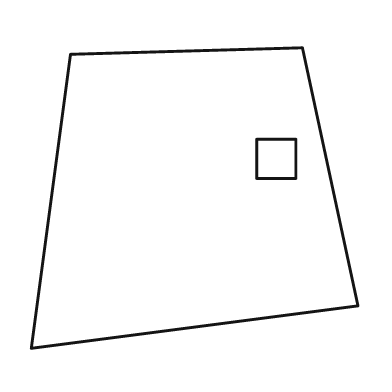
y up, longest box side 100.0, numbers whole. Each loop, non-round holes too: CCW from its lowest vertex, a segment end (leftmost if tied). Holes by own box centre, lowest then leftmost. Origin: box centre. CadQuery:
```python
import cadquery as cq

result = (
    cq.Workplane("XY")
    .moveTo(-50.0, -46.0)
    .lineTo(50.0, -33.0)
    .lineTo(33.0, 46.0)
    .lineTo(-38.0, 44.0)
    .close()
    .moveTo(19.0, 6.0)
    .lineTo(31.0, 6.0)
    .lineTo(31.0, 18.0)
    .lineTo(19.0, 18.0)
    .close()
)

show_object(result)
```